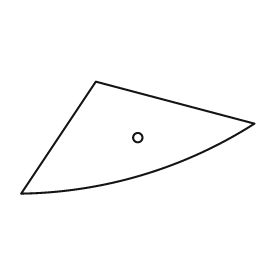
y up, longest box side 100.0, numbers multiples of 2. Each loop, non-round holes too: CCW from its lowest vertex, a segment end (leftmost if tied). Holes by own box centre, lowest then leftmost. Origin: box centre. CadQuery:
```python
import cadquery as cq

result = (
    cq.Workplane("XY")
    .moveTo(-50.0, -24.0)
    .threePointArc((2.0, -16.0), (50.0, 6.0))
    .lineTo(-18.0, 24.0)
    .close()
    .moveTo(0.0, 0.0)
    .circle(2.0)
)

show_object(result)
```